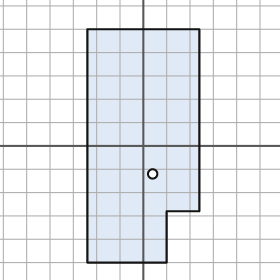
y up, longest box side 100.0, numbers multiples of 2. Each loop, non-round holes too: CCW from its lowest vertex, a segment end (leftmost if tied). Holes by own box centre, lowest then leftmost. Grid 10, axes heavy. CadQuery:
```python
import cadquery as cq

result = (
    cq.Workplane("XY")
    .moveTo(-24.0, -50.0)
    .lineTo(10.0, -50.0)
    .lineTo(10.0, -28.0)
    .lineTo(24.0, -28.0)
    .lineTo(24.0, 50.0)
    .lineTo(-24.0, 50.0)
    .close()
    .moveTo(4.0, -12.0)
    .circle(2.0)
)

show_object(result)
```